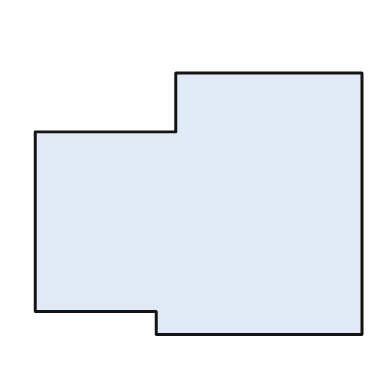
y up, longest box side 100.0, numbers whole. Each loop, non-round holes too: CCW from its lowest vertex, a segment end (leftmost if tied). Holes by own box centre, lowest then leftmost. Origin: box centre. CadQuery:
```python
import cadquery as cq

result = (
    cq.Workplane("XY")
    .moveTo(-13.0, -40.0)
    .lineTo(50.0, -40.0)
    .lineTo(50.0, 40.0)
    .lineTo(-7.0, 40.0)
    .lineTo(-7.0, 22.0)
    .lineTo(-50.0, 22.0)
    .lineTo(-50.0, -33.0)
    .lineTo(-13.0, -33.0)
    .close()
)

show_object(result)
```